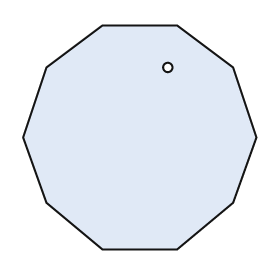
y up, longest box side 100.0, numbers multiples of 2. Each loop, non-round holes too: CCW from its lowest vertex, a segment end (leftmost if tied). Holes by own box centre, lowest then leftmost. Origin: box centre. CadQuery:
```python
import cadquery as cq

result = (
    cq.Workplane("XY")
    .moveTo(-16.0, -48.0)
    .lineTo(16.0, -48.0)
    .lineTo(40.0, -28.0)
    .lineTo(50.0, 0.0)
    .lineTo(40.0, 30.0)
    .lineTo(16.0, 48.0)
    .lineTo(-16.0, 48.0)
    .lineTo(-40.0, 30.0)
    .lineTo(-50.0, 0.0)
    .lineTo(-40.0, -28.0)
    .close()
    .moveTo(12.0, 30.0)
    .circle(2.0)
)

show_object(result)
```